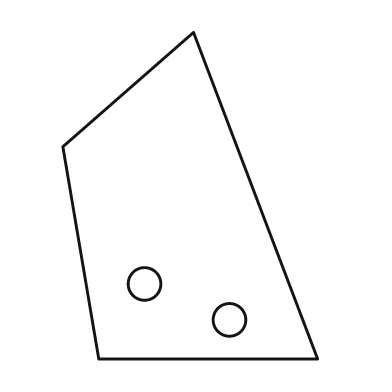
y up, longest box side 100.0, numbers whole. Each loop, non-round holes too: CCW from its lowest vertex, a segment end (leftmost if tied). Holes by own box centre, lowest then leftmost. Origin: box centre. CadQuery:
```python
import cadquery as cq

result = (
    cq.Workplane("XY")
    .moveTo(-28.0, -50.0)
    .lineTo(39.0, -50.0)
    .lineTo(1.0, 50.0)
    .lineTo(-39.0, 15.0)
    .close()
    .moveTo(12.0, -38.0)
    .circle(5.0)
    .moveTo(-14.0, -27.0)
    .circle(5.0)
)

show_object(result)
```